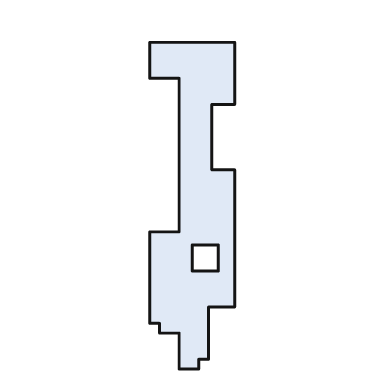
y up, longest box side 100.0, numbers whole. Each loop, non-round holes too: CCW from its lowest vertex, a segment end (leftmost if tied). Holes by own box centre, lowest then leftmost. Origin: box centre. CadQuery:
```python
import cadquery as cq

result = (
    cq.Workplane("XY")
    .moveTo(-4.0, -50.0)
    .lineTo(2.0, -50.0)
    .lineTo(2.0, -47.0)
    .lineTo(5.0, -47.0)
    .lineTo(5.0, -31.0)
    .lineTo(13.0, -31.0)
    .lineTo(13.0, 11.0)
    .lineTo(6.0, 11.0)
    .lineTo(6.0, 31.0)
    .lineTo(13.0, 31.0)
    .lineTo(13.0, 50.0)
    .lineTo(-13.0, 50.0)
    .lineTo(-13.0, 39.0)
    .lineTo(-4.0, 39.0)
    .lineTo(-4.0, -8.0)
    .lineTo(-13.0, -8.0)
    .lineTo(-13.0, -36.0)
    .lineTo(-10.0, -36.0)
    .lineTo(-10.0, -39.0)
    .lineTo(-4.0, -39.0)
    .close()
    .moveTo(0.0, -20.0)
    .lineTo(8.0, -20.0)
    .lineTo(8.0, -12.0)
    .lineTo(0.0, -12.0)
    .close()
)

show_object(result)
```